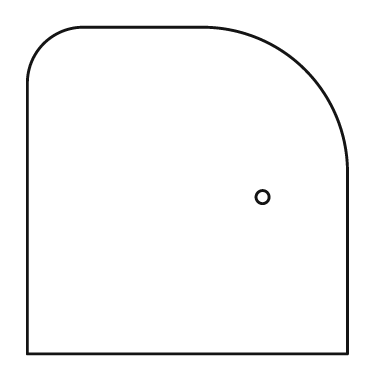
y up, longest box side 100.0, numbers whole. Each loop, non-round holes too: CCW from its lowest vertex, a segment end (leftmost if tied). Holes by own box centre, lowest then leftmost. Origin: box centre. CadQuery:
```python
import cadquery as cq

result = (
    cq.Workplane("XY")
    .moveTo(-49.0, -50.0)
    .lineTo(49.0, -50.0)
    .lineTo(49.0, 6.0)
    .threePointArc((36.0, 37.0), (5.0, 50.0))
    .lineTo(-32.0, 50.0)
    .threePointArc((-44.0, 45.0), (-49.0, 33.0))
    .close()
    .moveTo(23.0, -2.0)
    .circle(2.0)
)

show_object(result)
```